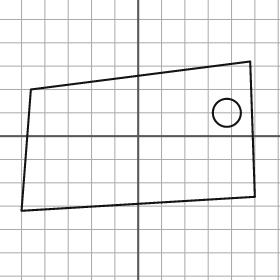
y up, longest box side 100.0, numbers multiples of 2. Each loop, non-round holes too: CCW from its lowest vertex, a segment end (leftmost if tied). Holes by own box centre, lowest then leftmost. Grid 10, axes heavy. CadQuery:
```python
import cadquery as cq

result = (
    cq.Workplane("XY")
    .moveTo(-50.0, -32.0)
    .lineTo(50.0, -26.0)
    .lineTo(48.0, 32.0)
    .lineTo(-46.0, 20.0)
    .close()
    .moveTo(38.0, 10.0)
    .circle(6.0)
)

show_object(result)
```